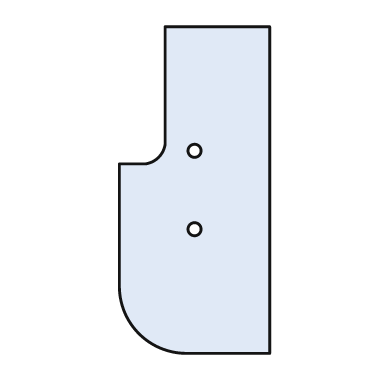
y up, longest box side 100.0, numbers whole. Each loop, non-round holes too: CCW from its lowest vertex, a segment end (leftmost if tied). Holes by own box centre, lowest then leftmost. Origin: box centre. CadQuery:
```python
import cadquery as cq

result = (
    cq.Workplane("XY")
    .moveTo(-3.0, -50.0)
    .lineTo(23.0, -50.0)
    .lineTo(23.0, 50.0)
    .lineTo(-9.0, 50.0)
    .lineTo(-9.0, 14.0)
    .threePointArc((-11.0, 10.0), (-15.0, 8.0))
    .lineTo(-23.0, 8.0)
    .lineTo(-23.0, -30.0)
    .threePointArc((-17.0, -44.0), (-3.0, -50.0))
    .close()
    .moveTo(0.0, -12.0)
    .circle(2.0)
    .moveTo(0.0, 12.0)
    .circle(2.0)
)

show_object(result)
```